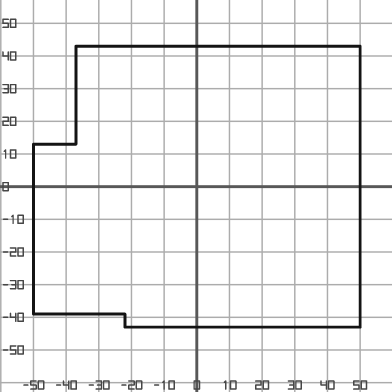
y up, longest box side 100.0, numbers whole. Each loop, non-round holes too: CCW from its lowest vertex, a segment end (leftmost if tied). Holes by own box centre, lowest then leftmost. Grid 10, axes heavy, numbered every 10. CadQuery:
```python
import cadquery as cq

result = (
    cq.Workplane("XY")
    .moveTo(-22.0, -43.0)
    .lineTo(50.0, -43.0)
    .lineTo(50.0, 43.0)
    .lineTo(-37.0, 43.0)
    .lineTo(-37.0, 13.0)
    .lineTo(-50.0, 13.0)
    .lineTo(-50.0, -39.0)
    .lineTo(-22.0, -39.0)
    .close()
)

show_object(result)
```